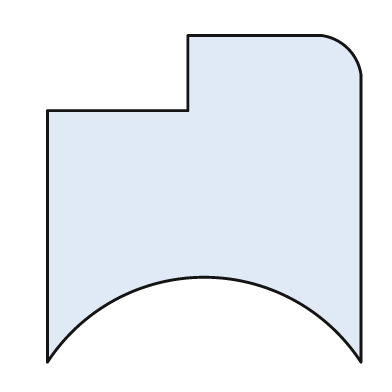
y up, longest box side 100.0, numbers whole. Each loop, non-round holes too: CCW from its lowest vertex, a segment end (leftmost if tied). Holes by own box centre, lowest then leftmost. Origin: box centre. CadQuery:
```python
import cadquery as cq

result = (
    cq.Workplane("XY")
    .moveTo(-48.0, -50.0)
    .threePointArc((0.0, -24.0), (48.0, -50.0))
    .lineTo(48.0, 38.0)
    .threePointArc((44.0, 46.0), (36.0, 50.0))
    .lineTo(-5.0, 50.0)
    .lineTo(-5.0, 27.0)
    .lineTo(-48.0, 27.0)
    .close()
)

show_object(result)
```